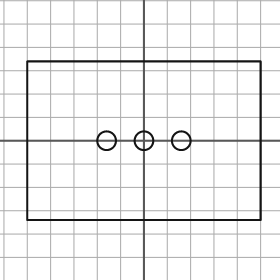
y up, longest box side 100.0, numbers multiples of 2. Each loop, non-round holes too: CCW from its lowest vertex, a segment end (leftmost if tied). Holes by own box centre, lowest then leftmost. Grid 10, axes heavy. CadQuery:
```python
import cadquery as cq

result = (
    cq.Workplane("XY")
    .moveTo(-50.0, -34.0)
    .lineTo(50.0, -34.0)
    .lineTo(50.0, 34.0)
    .lineTo(-50.0, 34.0)
    .close()
    .moveTo(-16.0, 0.0)
    .circle(4.0)
    .moveTo(0.0, 0.0)
    .circle(4.0)
    .moveTo(16.0, 0.0)
    .circle(4.0)
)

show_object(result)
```